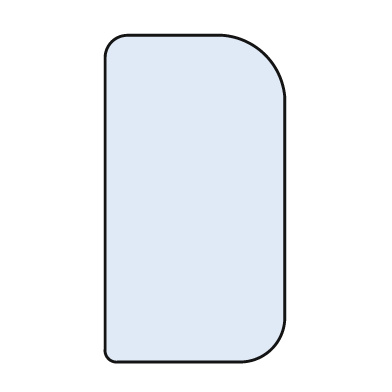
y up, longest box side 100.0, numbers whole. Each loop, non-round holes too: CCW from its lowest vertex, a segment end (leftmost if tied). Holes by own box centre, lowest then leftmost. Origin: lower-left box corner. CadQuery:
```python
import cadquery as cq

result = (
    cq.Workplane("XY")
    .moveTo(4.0, 0.0)
    .lineTo(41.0, 0.0)
    .threePointArc((51.0, 4.0), (55.0, 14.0))
    .lineTo(55.0, 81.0)
    .threePointArc((49.0, 94.0), (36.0, 100.0))
    .lineTo(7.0, 100.0)
    .threePointArc((2.0, 98.0), (0.0, 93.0))
    .lineTo(0.0, 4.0)
    .threePointArc((1.0, 1.0), (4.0, 0.0))
    .close()
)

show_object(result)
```